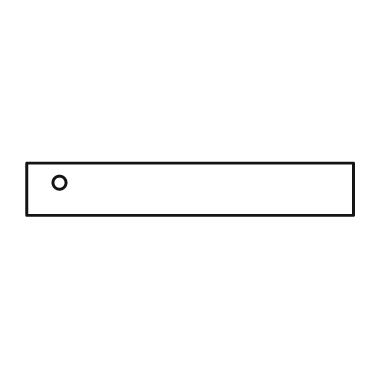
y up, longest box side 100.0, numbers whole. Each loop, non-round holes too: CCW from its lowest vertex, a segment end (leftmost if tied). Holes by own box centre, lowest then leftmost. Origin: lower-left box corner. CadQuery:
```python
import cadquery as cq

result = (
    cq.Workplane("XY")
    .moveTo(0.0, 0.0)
    .lineTo(100.0, 0.0)
    .lineTo(100.0, 16.0)
    .lineTo(0.0, 16.0)
    .close()
    .moveTo(10.0, 10.0)
    .circle(2.0)
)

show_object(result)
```